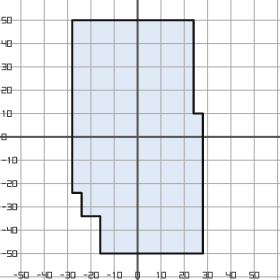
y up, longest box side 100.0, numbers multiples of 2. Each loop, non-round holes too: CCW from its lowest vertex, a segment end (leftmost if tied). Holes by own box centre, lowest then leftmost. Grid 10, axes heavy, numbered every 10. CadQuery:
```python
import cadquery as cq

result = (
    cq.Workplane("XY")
    .moveTo(-16.0, -50.0)
    .lineTo(28.0, -50.0)
    .lineTo(28.0, 10.0)
    .lineTo(24.0, 10.0)
    .lineTo(24.0, 50.0)
    .lineTo(-28.0, 50.0)
    .lineTo(-28.0, -24.0)
    .lineTo(-24.0, -24.0)
    .lineTo(-24.0, -34.0)
    .lineTo(-16.0, -34.0)
    .close()
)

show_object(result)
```